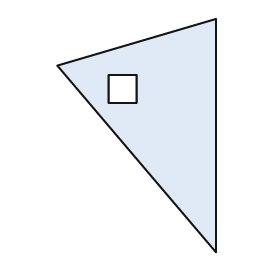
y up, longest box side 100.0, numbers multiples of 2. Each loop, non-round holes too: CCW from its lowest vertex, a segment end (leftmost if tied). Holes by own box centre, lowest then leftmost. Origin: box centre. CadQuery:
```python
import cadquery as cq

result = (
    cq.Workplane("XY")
    .moveTo(34.0, -50.0)
    .lineTo(34.0, 50.0)
    .lineTo(-34.0, 30.0)
    .close()
    .moveTo(-12.0, 14.0)
    .lineTo(0.0, 14.0)
    .lineTo(0.0, 26.0)
    .lineTo(-12.0, 26.0)
    .close()
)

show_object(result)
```